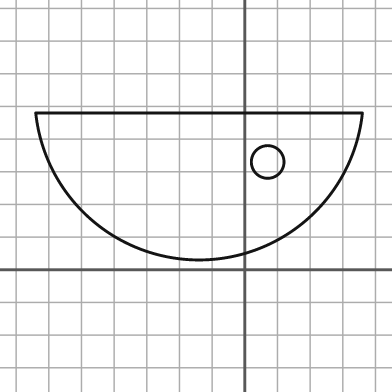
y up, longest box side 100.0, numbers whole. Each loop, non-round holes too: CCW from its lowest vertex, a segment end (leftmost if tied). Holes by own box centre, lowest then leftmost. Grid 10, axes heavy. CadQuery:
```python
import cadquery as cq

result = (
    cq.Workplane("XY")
    .moveTo(-64.0, 48.0)
    .threePointArc((-14.0, 3.0), (36.0, 48.0))
    .close()
    .moveTo(7.0, 33.0)
    .circle(5.0)
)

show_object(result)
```